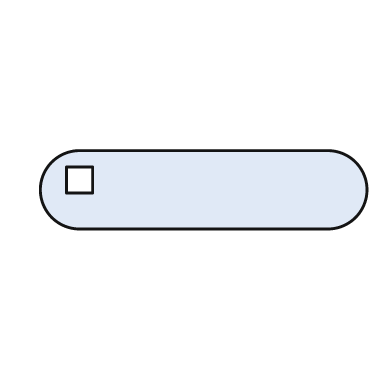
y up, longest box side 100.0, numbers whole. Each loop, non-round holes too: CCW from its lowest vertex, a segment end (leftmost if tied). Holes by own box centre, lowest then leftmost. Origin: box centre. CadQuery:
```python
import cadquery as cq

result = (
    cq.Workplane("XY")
    .moveTo(-38.0, -12.0)
    .lineTo(38.0, -12.0)
    .threePointArc((50.0, 0.0), (38.0, 12.0))
    .lineTo(-38.0, 12.0)
    .threePointArc((-50.0, 0.0), (-38.0, -12.0))
    .close()
    .moveTo(-42.0, -1.0)
    .lineTo(-34.0, -1.0)
    .lineTo(-34.0, 7.0)
    .lineTo(-42.0, 7.0)
    .close()
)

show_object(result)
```